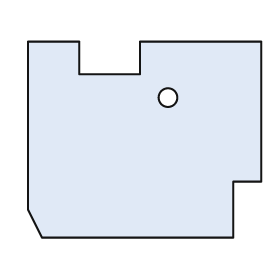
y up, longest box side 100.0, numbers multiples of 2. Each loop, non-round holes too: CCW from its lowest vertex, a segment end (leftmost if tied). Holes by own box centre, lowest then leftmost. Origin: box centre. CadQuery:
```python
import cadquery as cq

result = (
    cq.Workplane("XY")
    .moveTo(-44.0, -42.0)
    .lineTo(38.0, -42.0)
    .lineTo(38.0, -18.0)
    .lineTo(50.0, -18.0)
    .lineTo(50.0, 42.0)
    .lineTo(-2.0, 42.0)
    .lineTo(-2.0, 28.0)
    .lineTo(-28.0, 28.0)
    .lineTo(-28.0, 42.0)
    .lineTo(-50.0, 42.0)
    .lineTo(-50.0, -30.0)
    .close()
    .moveTo(10.0, 18.0)
    .circle(4.0)
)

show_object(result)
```